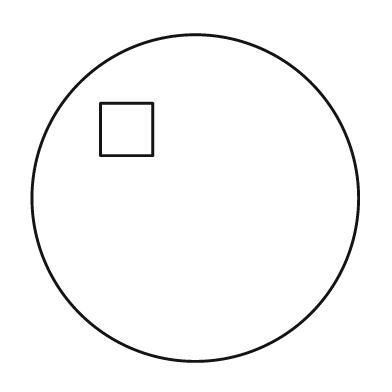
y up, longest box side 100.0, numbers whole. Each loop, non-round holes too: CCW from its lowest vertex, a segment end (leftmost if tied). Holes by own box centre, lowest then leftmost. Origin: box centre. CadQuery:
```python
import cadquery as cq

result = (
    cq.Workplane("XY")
    .moveTo(0.0, 0.0)
    .circle(50.0)
    .moveTo(-29.0, 13.0)
    .lineTo(-13.0, 13.0)
    .lineTo(-13.0, 29.0)
    .lineTo(-29.0, 29.0)
    .close()
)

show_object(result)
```